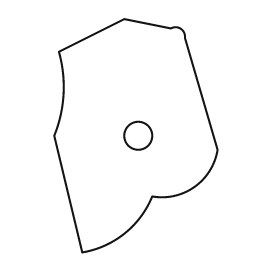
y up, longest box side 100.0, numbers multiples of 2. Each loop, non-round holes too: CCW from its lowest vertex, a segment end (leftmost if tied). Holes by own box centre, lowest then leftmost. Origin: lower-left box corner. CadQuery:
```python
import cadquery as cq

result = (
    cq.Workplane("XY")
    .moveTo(12.0, 0.0)
    .threePointArc((30.0, 8.0), (42.0, 24.0))
    .threePointArc((60.0, 28.0), (70.0, 44.0))
    .lineTo(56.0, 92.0)
    .threePointArc((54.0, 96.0), (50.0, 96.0))
    .lineTo(30.0, 100.0)
    .lineTo(2.0, 86.0)
    .threePointArc((4.0, 68.0), (0.0, 50.0))
    .close()
    .moveTo(36.0, 50.0)
    .circle(6.0)
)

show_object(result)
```